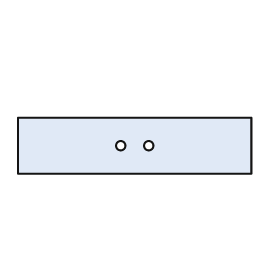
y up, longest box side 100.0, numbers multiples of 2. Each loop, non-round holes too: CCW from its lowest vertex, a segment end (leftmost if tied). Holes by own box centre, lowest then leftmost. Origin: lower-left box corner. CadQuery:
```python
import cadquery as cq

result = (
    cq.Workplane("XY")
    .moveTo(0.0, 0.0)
    .lineTo(100.0, 0.0)
    .lineTo(100.0, 24.0)
    .lineTo(0.0, 24.0)
    .close()
    .moveTo(44.0, 12.0)
    .circle(2.0)
    .moveTo(56.0, 12.0)
    .circle(2.0)
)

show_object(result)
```